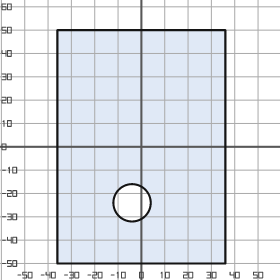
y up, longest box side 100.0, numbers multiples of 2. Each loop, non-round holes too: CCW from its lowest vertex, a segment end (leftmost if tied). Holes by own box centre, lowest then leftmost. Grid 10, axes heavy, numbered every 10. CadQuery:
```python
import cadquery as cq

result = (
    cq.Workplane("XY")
    .moveTo(-36.0, -50.0)
    .lineTo(36.0, -50.0)
    .lineTo(36.0, 50.0)
    .lineTo(-36.0, 50.0)
    .close()
    .moveTo(-4.0, -24.0)
    .circle(8.0)
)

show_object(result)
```